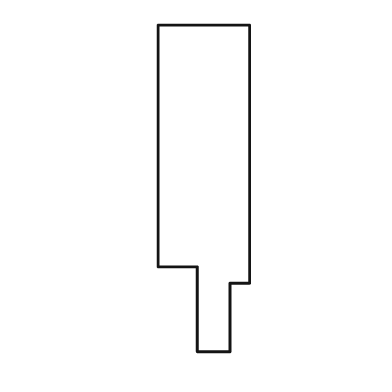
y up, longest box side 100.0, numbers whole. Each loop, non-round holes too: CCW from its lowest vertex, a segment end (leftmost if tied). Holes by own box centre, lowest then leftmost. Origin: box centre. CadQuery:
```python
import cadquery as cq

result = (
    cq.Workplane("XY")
    .moveTo(-2.0, -50.0)
    .lineTo(8.0, -50.0)
    .lineTo(8.0, -29.0)
    .lineTo(14.0, -29.0)
    .lineTo(14.0, 50.0)
    .lineTo(-14.0, 50.0)
    .lineTo(-14.0, -24.0)
    .lineTo(-2.0, -24.0)
    .close()
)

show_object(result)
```